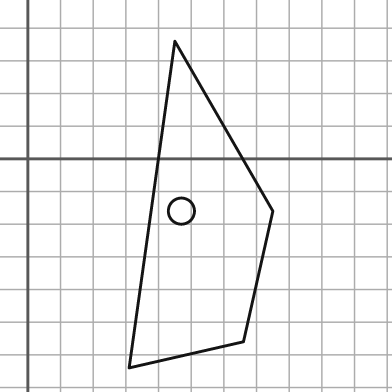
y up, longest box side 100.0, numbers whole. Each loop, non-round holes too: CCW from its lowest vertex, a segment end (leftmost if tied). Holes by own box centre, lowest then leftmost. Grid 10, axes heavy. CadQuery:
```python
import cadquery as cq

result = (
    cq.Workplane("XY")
    .moveTo(31.0, -64.0)
    .lineTo(66.0, -56.0)
    .lineTo(75.0, -16.0)
    .lineTo(45.0, 36.0)
    .close()
    .moveTo(47.0, -16.0)
    .circle(4.0)
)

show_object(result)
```